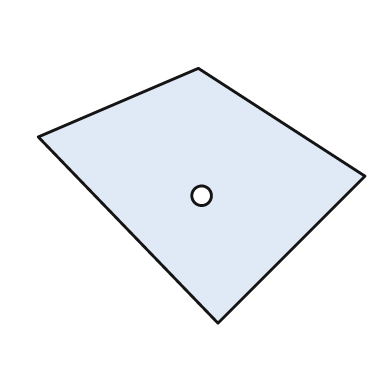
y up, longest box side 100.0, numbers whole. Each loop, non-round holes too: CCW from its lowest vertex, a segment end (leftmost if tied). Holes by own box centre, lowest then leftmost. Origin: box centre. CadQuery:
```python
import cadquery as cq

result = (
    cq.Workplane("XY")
    .moveTo(5.0, -39.0)
    .lineTo(50.0, 6.0)
    .lineTo(-1.0, 39.0)
    .lineTo(-50.0, 18.0)
    .close()
    .moveTo(0.0, 0.0)
    .circle(3.0)
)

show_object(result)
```